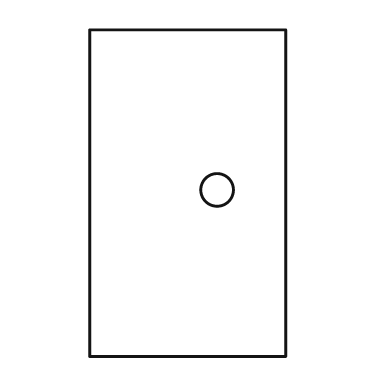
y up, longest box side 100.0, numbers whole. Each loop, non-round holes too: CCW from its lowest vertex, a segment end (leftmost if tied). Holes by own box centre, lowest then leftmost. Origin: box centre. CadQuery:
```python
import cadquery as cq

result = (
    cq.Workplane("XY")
    .moveTo(-30.0, -50.0)
    .lineTo(30.0, -50.0)
    .lineTo(30.0, 50.0)
    .lineTo(-30.0, 50.0)
    .close()
    .moveTo(9.0, 1.0)
    .circle(5.0)
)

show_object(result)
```